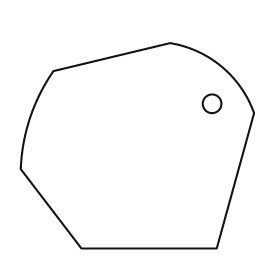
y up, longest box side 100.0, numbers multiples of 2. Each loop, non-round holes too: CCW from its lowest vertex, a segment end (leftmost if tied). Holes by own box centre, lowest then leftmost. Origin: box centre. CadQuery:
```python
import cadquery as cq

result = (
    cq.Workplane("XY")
    .moveTo(-24.0, -44.0)
    .lineTo(34.0, -44.0)
    .lineTo(50.0, 14.0)
    .threePointArc((36.0, 34.0), (14.0, 44.0))
    .lineTo(-36.0, 32.0)
    .threePointArc((-46.0, 12.0), (-50.0, -10.0))
    .close()
    .moveTo(32.0, 18.0)
    .circle(4.0)
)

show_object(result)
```